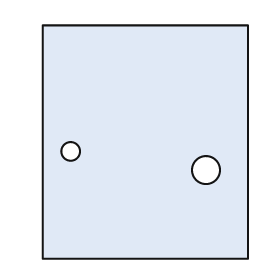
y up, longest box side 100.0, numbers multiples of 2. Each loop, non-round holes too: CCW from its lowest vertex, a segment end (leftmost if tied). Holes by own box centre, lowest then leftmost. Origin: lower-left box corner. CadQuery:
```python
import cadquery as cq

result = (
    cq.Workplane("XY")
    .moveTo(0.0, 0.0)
    .lineTo(88.0, 0.0)
    .lineTo(88.0, 100.0)
    .lineTo(0.0, 100.0)
    .close()
    .moveTo(70.0, 38.0)
    .circle(6.0)
    .moveTo(12.0, 46.0)
    .circle(4.0)
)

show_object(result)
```